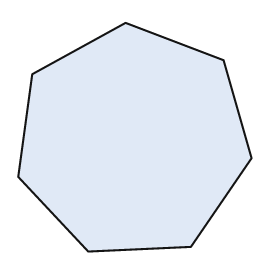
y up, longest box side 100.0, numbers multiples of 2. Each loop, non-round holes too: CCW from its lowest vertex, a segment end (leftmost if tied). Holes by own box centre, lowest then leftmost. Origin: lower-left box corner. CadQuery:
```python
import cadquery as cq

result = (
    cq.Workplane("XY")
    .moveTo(30.0, 0.0)
    .lineTo(74.0, 2.0)
    .lineTo(100.0, 40.0)
    .lineTo(88.0, 82.0)
    .lineTo(46.0, 98.0)
    .lineTo(6.0, 76.0)
    .lineTo(0.0, 32.0)
    .close()
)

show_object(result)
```